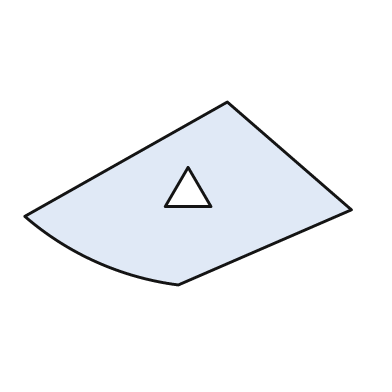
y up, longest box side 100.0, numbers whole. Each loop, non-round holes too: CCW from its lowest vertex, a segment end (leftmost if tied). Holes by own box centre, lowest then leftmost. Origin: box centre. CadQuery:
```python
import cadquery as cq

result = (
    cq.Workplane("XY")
    .moveTo(-3.0, -28.0)
    .lineTo(50.0, -5.0)
    .lineTo(12.0, 28.0)
    .lineTo(-50.0, -7.0)
    .threePointArc((-28.0, -21.0), (-3.0, -28.0))
    .close()
    .moveTo(-7.0, -4.0)
    .lineTo(7.0, -4.0)
    .lineTo(0.0, 8.0)
    .close()
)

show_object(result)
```